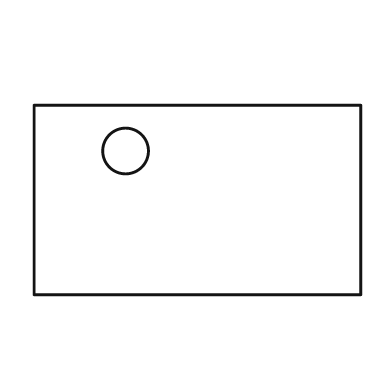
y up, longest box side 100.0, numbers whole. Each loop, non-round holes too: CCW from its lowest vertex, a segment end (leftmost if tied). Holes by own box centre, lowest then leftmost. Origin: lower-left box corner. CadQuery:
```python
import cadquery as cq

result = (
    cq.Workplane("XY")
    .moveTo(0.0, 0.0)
    .lineTo(100.0, 0.0)
    .lineTo(100.0, 58.0)
    .lineTo(0.0, 58.0)
    .close()
    .moveTo(28.0, 44.0)
    .circle(7.0)
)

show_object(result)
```